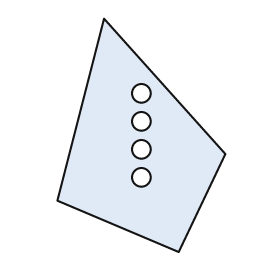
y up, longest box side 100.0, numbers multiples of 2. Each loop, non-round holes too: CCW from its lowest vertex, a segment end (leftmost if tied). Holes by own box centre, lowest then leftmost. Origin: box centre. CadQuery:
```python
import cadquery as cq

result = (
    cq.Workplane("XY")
    .moveTo(16.0, -50.0)
    .lineTo(36.0, -8.0)
    .lineTo(-16.0, 50.0)
    .lineTo(-36.0, -28.0)
    .close()
    .moveTo(0.0, -18.0)
    .circle(4.0)
    .moveTo(0.0, -6.0)
    .circle(4.0)
    .moveTo(0.0, 6.0)
    .circle(4.0)
    .moveTo(0.0, 18.0)
    .circle(4.0)
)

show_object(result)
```